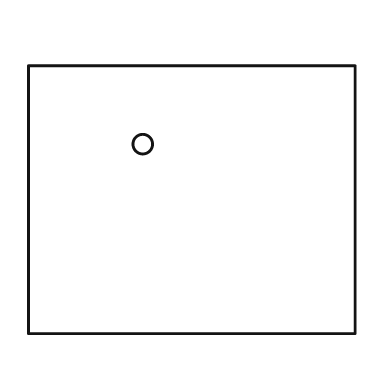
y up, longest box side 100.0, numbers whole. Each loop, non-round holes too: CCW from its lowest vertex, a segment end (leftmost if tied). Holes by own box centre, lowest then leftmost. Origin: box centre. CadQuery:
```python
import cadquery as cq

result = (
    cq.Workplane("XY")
    .moveTo(-50.0, -41.0)
    .lineTo(50.0, -41.0)
    .lineTo(50.0, 41.0)
    .lineTo(-50.0, 41.0)
    .close()
    .moveTo(-15.0, 17.0)
    .circle(3.0)
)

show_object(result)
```